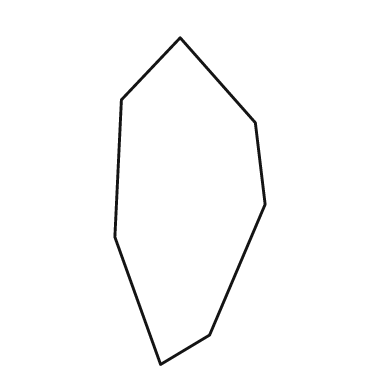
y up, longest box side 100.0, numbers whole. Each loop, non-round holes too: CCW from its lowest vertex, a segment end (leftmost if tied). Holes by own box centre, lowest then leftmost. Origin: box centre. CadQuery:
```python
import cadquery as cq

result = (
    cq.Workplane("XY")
    .moveTo(-9.0, -50.0)
    .lineTo(6.0, -41.0)
    .lineTo(23.0, -1.0)
    .lineTo(20.0, 24.0)
    .lineTo(-3.0, 50.0)
    .lineTo(-21.0, 31.0)
    .lineTo(-23.0, -11.0)
    .close()
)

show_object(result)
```